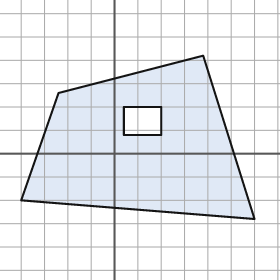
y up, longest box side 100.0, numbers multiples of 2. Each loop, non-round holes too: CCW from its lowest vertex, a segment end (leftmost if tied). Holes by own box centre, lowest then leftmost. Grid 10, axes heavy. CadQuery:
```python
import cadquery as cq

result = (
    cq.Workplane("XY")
    .moveTo(60.0, -28.0)
    .lineTo(38.0, 42.0)
    .lineTo(-24.0, 26.0)
    .lineTo(-40.0, -20.0)
    .close()
    .moveTo(4.0, 8.0)
    .lineTo(20.0, 8.0)
    .lineTo(20.0, 20.0)
    .lineTo(4.0, 20.0)
    .close()
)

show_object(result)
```